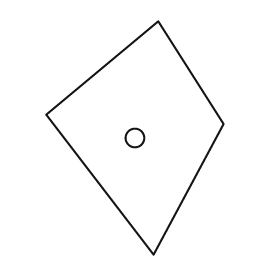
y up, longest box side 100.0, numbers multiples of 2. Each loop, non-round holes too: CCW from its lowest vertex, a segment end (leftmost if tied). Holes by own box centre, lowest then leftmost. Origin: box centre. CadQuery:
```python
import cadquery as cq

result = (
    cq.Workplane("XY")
    .moveTo(8.0, -50.0)
    .lineTo(38.0, 6.0)
    .lineTo(10.0, 50.0)
    .lineTo(-38.0, 10.0)
    .close()
    .moveTo(0.0, 0.0)
    .circle(4.0)
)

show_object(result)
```